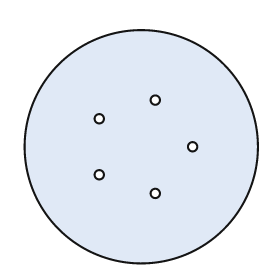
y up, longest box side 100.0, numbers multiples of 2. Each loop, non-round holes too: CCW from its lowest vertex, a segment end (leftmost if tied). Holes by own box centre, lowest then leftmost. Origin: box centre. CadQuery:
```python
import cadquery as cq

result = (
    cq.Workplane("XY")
    .moveTo(0.0, 0.0)
    .circle(50.0)
    .moveTo(6.0, -20.0)
    .circle(2.0)
    .moveTo(-18.0, -12.0)
    .circle(2.0)
    .moveTo(22.0, 0.0)
    .circle(2.0)
    .moveTo(-18.0, 12.0)
    .circle(2.0)
    .moveTo(6.0, 20.0)
    .circle(2.0)
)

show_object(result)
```